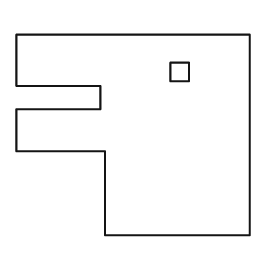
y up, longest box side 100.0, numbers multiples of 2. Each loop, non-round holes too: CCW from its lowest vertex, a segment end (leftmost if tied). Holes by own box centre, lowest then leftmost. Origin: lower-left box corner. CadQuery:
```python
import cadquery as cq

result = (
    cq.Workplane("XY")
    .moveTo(38.0, 0.0)
    .lineTo(100.0, 0.0)
    .lineTo(100.0, 86.0)
    .lineTo(0.0, 86.0)
    .lineTo(0.0, 64.0)
    .lineTo(36.0, 64.0)
    .lineTo(36.0, 54.0)
    .lineTo(0.0, 54.0)
    .lineTo(0.0, 36.0)
    .lineTo(38.0, 36.0)
    .close()
    .moveTo(66.0, 66.0)
    .lineTo(74.0, 66.0)
    .lineTo(74.0, 74.0)
    .lineTo(66.0, 74.0)
    .close()
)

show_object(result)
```